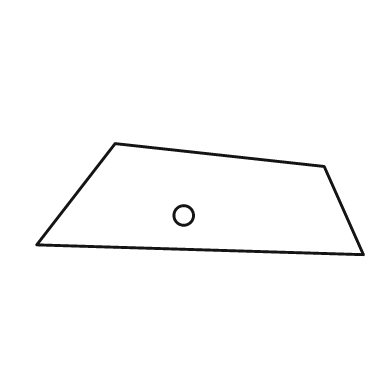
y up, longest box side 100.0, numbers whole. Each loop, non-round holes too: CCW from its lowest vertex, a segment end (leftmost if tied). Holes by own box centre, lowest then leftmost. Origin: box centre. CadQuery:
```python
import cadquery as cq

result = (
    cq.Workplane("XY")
    .moveTo(50.0, -17.0)
    .lineTo(38.0, 10.0)
    .lineTo(-26.0, 17.0)
    .lineTo(-50.0, -14.0)
    .close()
    .moveTo(-5.0, -5.0)
    .circle(3.0)
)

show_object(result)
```